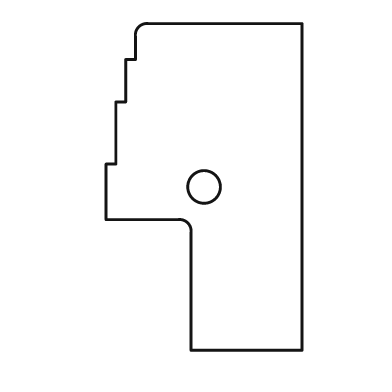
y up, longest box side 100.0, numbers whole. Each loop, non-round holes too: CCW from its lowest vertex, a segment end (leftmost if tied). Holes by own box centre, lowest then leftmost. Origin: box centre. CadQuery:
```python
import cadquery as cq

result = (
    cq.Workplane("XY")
    .moveTo(-4.0, -50.0)
    .lineTo(30.0, -50.0)
    .lineTo(30.0, 50.0)
    .lineTo(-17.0, 50.0)
    .threePointArc((-20.0, 49.0), (-21.0, 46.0))
    .lineTo(-21.0, 39.0)
    .lineTo(-24.0, 39.0)
    .lineTo(-24.0, 26.0)
    .lineTo(-27.0, 26.0)
    .lineTo(-27.0, 7.0)
    .lineTo(-30.0, 7.0)
    .lineTo(-30.0, -10.0)
    .lineTo(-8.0, -10.0)
    .threePointArc((-5.0, -11.0), (-4.0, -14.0))
    .close()
    .moveTo(0.0, 0.0)
    .circle(5.0)
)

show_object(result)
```